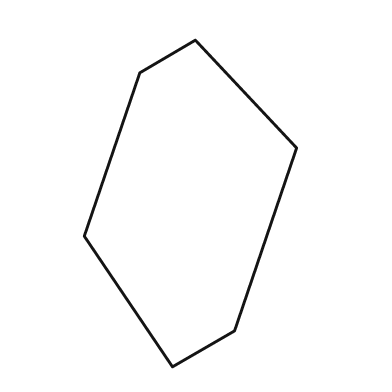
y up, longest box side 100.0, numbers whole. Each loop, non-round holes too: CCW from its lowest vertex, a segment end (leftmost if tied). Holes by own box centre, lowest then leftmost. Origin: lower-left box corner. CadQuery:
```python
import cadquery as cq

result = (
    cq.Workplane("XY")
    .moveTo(27.0, 0.0)
    .lineTo(46.0, 11.0)
    .lineTo(65.0, 67.0)
    .lineTo(34.0, 100.0)
    .lineTo(17.0, 90.0)
    .lineTo(0.0, 40.0)
    .close()
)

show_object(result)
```